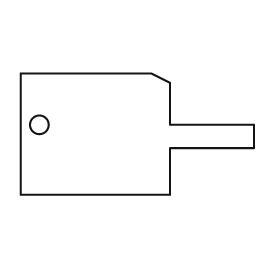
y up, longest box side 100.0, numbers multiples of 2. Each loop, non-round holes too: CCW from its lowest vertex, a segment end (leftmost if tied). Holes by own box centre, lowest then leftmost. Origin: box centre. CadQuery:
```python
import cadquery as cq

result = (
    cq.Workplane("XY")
    .moveTo(-50.0, -26.0)
    .lineTo(14.0, -26.0)
    .lineTo(14.0, -6.0)
    .lineTo(50.0, -6.0)
    .lineTo(50.0, 4.0)
    .lineTo(14.0, 4.0)
    .lineTo(14.0, 22.0)
    .lineTo(6.0, 26.0)
    .lineTo(-50.0, 26.0)
    .close()
    .moveTo(-42.0, 4.0)
    .circle(4.0)
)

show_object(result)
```